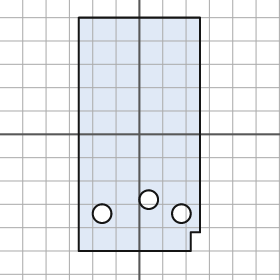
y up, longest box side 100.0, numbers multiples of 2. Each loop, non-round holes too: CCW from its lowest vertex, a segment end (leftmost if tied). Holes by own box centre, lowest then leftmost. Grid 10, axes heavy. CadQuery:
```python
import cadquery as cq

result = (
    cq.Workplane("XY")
    .moveTo(-26.0, -50.0)
    .lineTo(22.0, -50.0)
    .lineTo(22.0, -42.0)
    .lineTo(26.0, -42.0)
    .lineTo(26.0, 50.0)
    .lineTo(-26.0, 50.0)
    .close()
    .moveTo(-16.0, -34.0)
    .circle(4.0)
    .moveTo(18.0, -34.0)
    .circle(4.0)
    .moveTo(4.0, -28.0)
    .circle(4.0)
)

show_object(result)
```